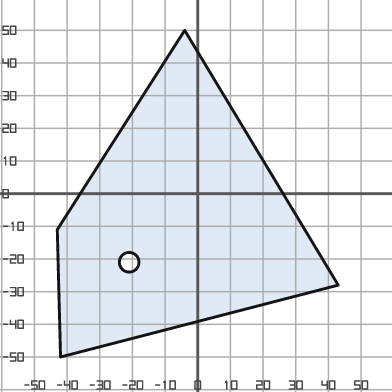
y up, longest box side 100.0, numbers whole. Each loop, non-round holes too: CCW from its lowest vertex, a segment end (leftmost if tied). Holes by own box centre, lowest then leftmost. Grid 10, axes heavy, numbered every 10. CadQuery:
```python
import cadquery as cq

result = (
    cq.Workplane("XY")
    .moveTo(-42.0, -50.0)
    .lineTo(43.0, -28.0)
    .lineTo(-4.0, 50.0)
    .lineTo(-43.0, -11.0)
    .close()
    .moveTo(-21.0, -21.0)
    .circle(3.0)
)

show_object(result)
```